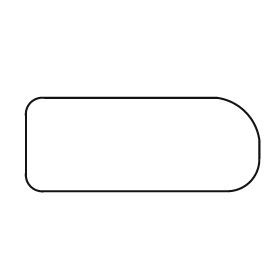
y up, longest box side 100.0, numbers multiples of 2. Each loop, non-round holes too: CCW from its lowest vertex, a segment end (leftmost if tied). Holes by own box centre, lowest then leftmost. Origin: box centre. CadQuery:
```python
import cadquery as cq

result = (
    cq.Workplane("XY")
    .moveTo(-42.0, -20.0)
    .lineTo(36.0, -20.0)
    .threePointArc((46.0, -16.0), (50.0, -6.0))
    .lineTo(50.0, 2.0)
    .threePointArc((44.0, 14.0), (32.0, 20.0))
    .lineTo(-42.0, 20.0)
    .threePointArc((-48.0, 18.0), (-50.0, 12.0))
    .lineTo(-50.0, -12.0)
    .threePointArc((-48.0, -18.0), (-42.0, -20.0))
    .close()
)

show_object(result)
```